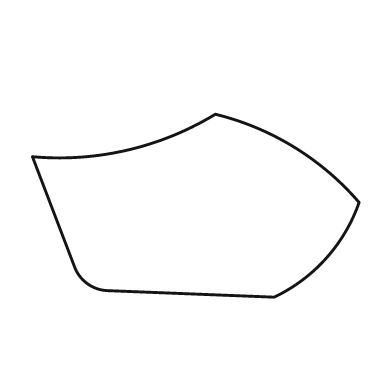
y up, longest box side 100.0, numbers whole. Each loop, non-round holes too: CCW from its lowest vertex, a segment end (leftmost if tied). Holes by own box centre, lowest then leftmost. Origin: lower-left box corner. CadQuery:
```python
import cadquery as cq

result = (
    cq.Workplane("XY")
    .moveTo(74.0, 0.0)
    .threePointArc((90.0, 12.0), (100.0, 29.0))
    .threePointArc((80.0, 46.0), (56.0, 56.0))
    .threePointArc((29.0, 45.0), (0.0, 43.0))
    .lineTo(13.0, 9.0)
    .threePointArc((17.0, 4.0), (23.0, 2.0))
    .close()
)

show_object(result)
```